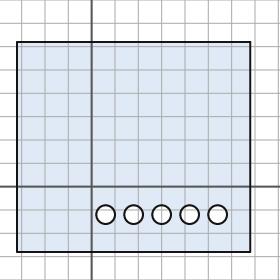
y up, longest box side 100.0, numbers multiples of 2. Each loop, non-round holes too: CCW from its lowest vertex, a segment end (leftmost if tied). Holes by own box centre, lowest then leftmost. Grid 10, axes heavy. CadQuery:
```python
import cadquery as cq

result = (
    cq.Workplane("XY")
    .moveTo(-32.0, -28.0)
    .lineTo(68.0, -28.0)
    .lineTo(68.0, 62.0)
    .lineTo(-32.0, 62.0)
    .close()
    .moveTo(6.0, -12.0)
    .circle(4.0)
    .moveTo(18.0, -12.0)
    .circle(4.0)
    .moveTo(30.0, -12.0)
    .circle(4.0)
    .moveTo(42.0, -12.0)
    .circle(4.0)
    .moveTo(54.0, -12.0)
    .circle(4.0)
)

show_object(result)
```